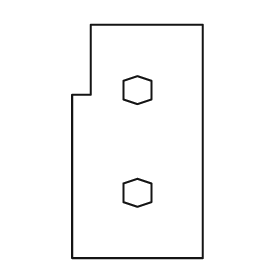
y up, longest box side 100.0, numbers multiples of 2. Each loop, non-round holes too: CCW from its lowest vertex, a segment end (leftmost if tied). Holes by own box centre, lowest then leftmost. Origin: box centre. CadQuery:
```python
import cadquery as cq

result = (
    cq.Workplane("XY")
    .moveTo(-28.0, -50.0)
    .lineTo(28.0, -50.0)
    .lineTo(28.0, 50.0)
    .lineTo(-20.0, 50.0)
    .lineTo(-20.0, 20.0)
    .lineTo(-28.0, 20.0)
    .close()
    .moveTo(0.0, -28.0)
    .lineTo(6.0, -26.0)
    .lineTo(6.0, -18.0)
    .lineTo(0.0, -16.0)
    .lineTo(-6.0, -18.0)
    .lineTo(-6.0, -26.0)
    .close()
    .moveTo(0.0, 16.0)
    .lineTo(6.0, 18.0)
    .lineTo(6.0, 26.0)
    .lineTo(0.0, 28.0)
    .lineTo(-6.0, 26.0)
    .lineTo(-6.0, 18.0)
    .close()
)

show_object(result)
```